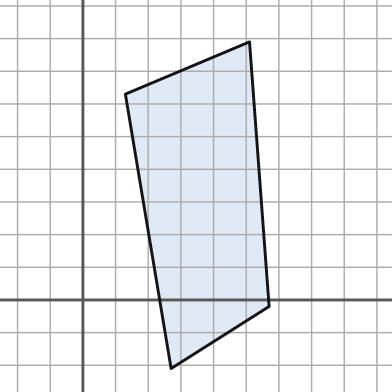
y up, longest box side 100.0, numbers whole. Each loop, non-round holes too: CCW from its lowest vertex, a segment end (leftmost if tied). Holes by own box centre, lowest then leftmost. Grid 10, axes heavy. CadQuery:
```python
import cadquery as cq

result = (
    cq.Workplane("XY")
    .moveTo(27.0, -21.0)
    .lineTo(57.0, -2.0)
    .lineTo(51.0, 79.0)
    .lineTo(13.0, 63.0)
    .close()
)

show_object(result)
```